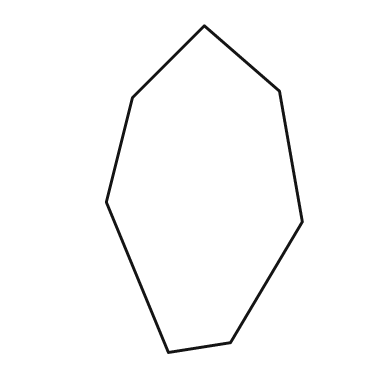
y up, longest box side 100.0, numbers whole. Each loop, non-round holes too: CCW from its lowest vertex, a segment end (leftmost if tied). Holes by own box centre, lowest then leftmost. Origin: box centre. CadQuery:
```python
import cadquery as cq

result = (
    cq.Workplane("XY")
    .moveTo(-11.0, -50.0)
    .lineTo(8.0, -47.0)
    .lineTo(30.0, -10.0)
    .lineTo(23.0, 30.0)
    .lineTo(0.0, 50.0)
    .lineTo(-22.0, 28.0)
    .lineTo(-30.0, -4.0)
    .close()
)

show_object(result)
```